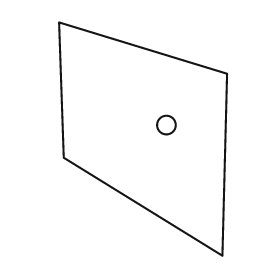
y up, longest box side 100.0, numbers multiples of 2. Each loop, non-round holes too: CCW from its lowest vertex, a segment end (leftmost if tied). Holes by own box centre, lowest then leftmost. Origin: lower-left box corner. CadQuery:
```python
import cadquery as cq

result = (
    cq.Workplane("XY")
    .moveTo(70.0, 0.0)
    .lineTo(72.0, 78.0)
    .lineTo(0.0, 100.0)
    .lineTo(2.0, 42.0)
    .close()
    .moveTo(46.0, 56.0)
    .circle(4.0)
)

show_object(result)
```